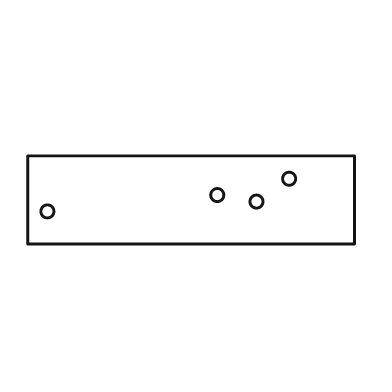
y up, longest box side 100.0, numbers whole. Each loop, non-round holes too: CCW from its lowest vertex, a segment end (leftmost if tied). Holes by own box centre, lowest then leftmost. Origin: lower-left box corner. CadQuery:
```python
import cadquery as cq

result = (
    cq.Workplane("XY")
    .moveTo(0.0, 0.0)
    .lineTo(100.0, 0.0)
    .lineTo(100.0, 27.0)
    .lineTo(0.0, 27.0)
    .close()
    .moveTo(6.0, 10.0)
    .circle(2.0)
    .moveTo(70.0, 13.0)
    .circle(2.0)
    .moveTo(58.0, 15.0)
    .circle(2.0)
    .moveTo(80.0, 20.0)
    .circle(2.0)
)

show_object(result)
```